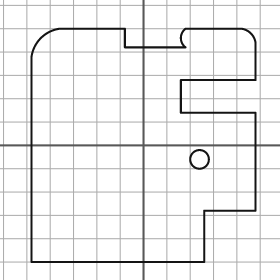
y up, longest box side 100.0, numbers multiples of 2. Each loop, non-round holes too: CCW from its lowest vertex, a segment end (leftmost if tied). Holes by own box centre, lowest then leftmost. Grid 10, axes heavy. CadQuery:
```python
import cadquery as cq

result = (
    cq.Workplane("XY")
    .moveTo(-48.0, -50.0)
    .lineTo(26.0, -50.0)
    .lineTo(26.0, -28.0)
    .lineTo(48.0, -28.0)
    .lineTo(48.0, 14.0)
    .lineTo(16.0, 14.0)
    .lineTo(16.0, 28.0)
    .lineTo(48.0, 28.0)
    .lineTo(48.0, 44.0)
    .threePointArc((46.0, 48.0), (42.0, 50.0))
    .lineTo(18.0, 50.0)
    .threePointArc((16.0, 46.0), (18.0, 42.0))
    .lineTo(-8.0, 42.0)
    .lineTo(-8.0, 50.0)
    .lineTo(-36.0, 50.0)
    .threePointArc((-44.0, 46.0), (-48.0, 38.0))
    .close()
    .moveTo(24.0, -6.0)
    .circle(4.0)
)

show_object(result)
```